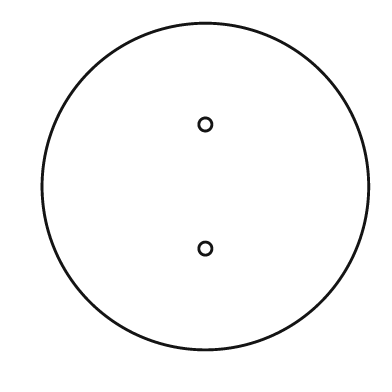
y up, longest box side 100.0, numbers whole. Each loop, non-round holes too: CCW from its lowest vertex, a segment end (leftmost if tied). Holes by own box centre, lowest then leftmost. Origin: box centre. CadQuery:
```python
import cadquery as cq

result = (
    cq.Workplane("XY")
    .moveTo(0.0, 0.0)
    .circle(50.0)
    .moveTo(0.0, -19.0)
    .circle(2.0)
    .moveTo(0.0, 19.0)
    .circle(2.0)
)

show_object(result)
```